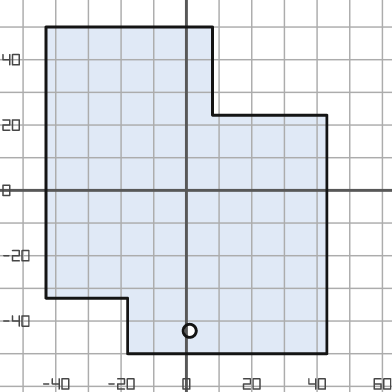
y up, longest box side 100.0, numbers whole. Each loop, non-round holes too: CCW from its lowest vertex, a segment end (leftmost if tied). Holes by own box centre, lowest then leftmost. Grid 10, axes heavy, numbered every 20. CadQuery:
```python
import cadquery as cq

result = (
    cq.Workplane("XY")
    .moveTo(-18.0, -50.0)
    .lineTo(43.0, -50.0)
    .lineTo(43.0, 23.0)
    .lineTo(8.0, 23.0)
    .lineTo(8.0, 50.0)
    .lineTo(-43.0, 50.0)
    .lineTo(-43.0, -33.0)
    .lineTo(-18.0, -33.0)
    .close()
    .moveTo(1.0, -43.0)
    .circle(2.0)
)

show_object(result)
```